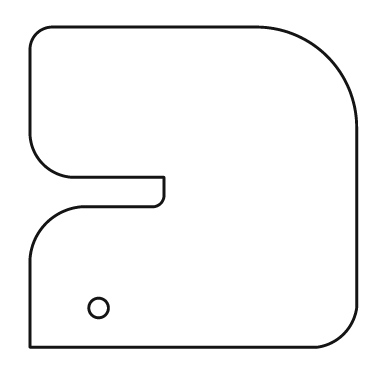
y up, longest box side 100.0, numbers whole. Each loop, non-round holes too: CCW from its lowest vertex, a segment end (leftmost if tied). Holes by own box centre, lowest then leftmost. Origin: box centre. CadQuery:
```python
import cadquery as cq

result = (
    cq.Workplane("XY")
    .moveTo(-50.0, -49.0)
    .lineTo(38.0, -49.0)
    .threePointArc((46.0, -45.0), (50.0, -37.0))
    .lineTo(50.0, 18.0)
    .threePointArc((41.0, 40.0), (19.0, 49.0))
    .lineTo(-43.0, 49.0)
    .threePointArc((-48.0, 47.0), (-50.0, 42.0))
    .lineTo(-50.0, 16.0)
    .threePointArc((-46.0, 7.0), (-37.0, 3.0))
    .lineTo(-9.0, 3.0)
    .lineTo(-9.0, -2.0)
    .threePointArc((-10.0, -5.0), (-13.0, -6.0))
    .lineTo(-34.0, -6.0)
    .threePointArc((-45.0, -11.0), (-50.0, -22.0))
    .close()
    .moveTo(-29.0, -37.0)
    .circle(3.0)
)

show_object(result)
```